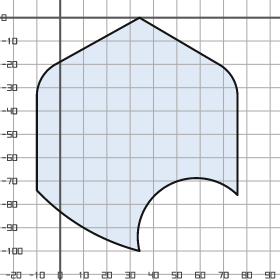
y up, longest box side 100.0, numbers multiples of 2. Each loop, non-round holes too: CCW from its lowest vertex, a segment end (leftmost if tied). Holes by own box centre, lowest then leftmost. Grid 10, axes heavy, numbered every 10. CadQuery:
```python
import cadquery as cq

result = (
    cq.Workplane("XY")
    .moveTo(34.0, -100.0)
    .threePointArc((46.0, -72.0), (76.0, -76.0))
    .lineTo(76.0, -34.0)
    .threePointArc((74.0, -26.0), (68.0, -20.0))
    .lineTo(34.0, 0.0)
    .lineTo(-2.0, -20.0)
    .threePointArc((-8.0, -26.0), (-10.0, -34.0))
    .lineTo(-10.0, -74.0)
    .threePointArc((10.0, -90.0), (34.0, -100.0))
    .close()
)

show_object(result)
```